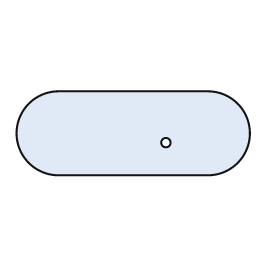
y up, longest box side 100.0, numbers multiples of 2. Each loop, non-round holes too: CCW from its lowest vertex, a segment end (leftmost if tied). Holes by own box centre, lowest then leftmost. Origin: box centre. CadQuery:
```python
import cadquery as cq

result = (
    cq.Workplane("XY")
    .moveTo(-32.0, -18.0)
    .lineTo(32.0, -18.0)
    .threePointArc((50.0, 0.0), (32.0, 18.0))
    .lineTo(-32.0, 18.0)
    .threePointArc((-50.0, 0.0), (-32.0, -18.0))
    .close()
    .moveTo(14.0, -4.0)
    .circle(2.0)
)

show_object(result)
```